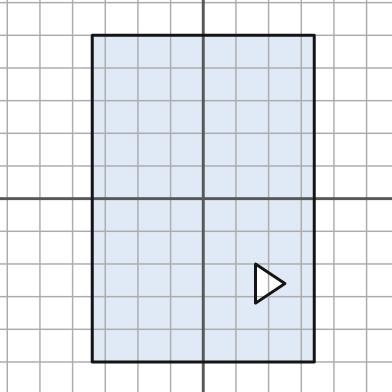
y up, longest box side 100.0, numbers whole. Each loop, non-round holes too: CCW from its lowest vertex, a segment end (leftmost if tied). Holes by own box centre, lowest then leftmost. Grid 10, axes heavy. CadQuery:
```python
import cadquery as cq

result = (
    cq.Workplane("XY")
    .moveTo(-34.0, -50.0)
    .lineTo(34.0, -50.0)
    .lineTo(34.0, 50.0)
    .lineTo(-34.0, 50.0)
    .close()
    .moveTo(16.0, -32.0)
    .lineTo(25.0, -26.0)
    .lineTo(16.0, -20.0)
    .close()
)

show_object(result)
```